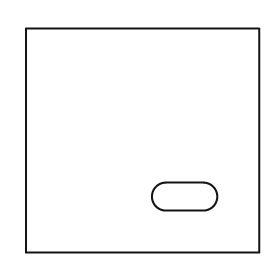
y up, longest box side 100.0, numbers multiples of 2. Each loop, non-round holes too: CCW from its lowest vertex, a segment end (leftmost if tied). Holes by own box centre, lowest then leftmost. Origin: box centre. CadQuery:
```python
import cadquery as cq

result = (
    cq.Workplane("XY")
    .moveTo(-50.0, -48.0)
    .lineTo(50.0, -48.0)
    .lineTo(50.0, 48.0)
    .lineTo(-50.0, 48.0)
    .close()
    .moveTo(10.0, -30.0)
    .lineTo(26.0, -30.0)
    .threePointArc((32.0, -24.0), (26.0, -18.0))
    .lineTo(10.0, -18.0)
    .threePointArc((4.0, -24.0), (10.0, -30.0))
    .close()
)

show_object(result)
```